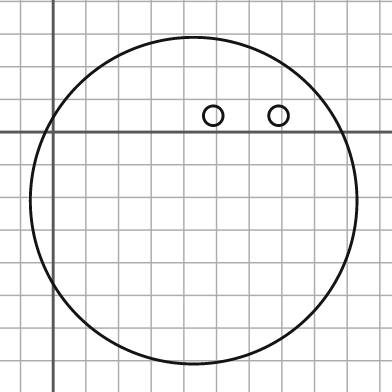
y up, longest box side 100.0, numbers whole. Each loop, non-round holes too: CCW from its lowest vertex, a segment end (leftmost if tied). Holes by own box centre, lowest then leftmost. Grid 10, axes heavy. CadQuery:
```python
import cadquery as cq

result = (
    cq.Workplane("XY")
    .moveTo(43.0, -21.0)
    .circle(50.0)
    .moveTo(49.0, 5.0)
    .circle(3.0)
    .moveTo(69.0, 5.0)
    .circle(3.0)
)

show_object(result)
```